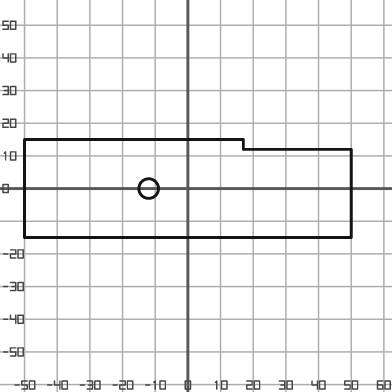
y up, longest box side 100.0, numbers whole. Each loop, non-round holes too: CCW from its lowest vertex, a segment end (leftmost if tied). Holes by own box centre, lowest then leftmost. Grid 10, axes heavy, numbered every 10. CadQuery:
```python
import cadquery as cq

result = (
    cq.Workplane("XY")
    .moveTo(-50.0, -15.0)
    .lineTo(50.0, -15.0)
    .lineTo(50.0, 12.0)
    .lineTo(17.0, 12.0)
    .lineTo(17.0, 15.0)
    .lineTo(-50.0, 15.0)
    .close()
    .moveTo(-12.0, 0.0)
    .circle(3.0)
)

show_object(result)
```